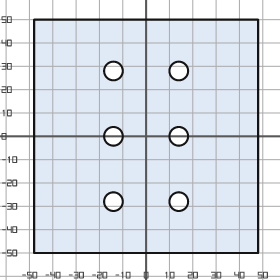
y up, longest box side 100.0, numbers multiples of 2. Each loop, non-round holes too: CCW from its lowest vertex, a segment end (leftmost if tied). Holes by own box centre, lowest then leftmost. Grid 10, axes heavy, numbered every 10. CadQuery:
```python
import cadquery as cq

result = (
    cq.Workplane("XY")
    .moveTo(-48.0, -50.0)
    .lineTo(48.0, -50.0)
    .lineTo(48.0, 50.0)
    .lineTo(-48.0, 50.0)
    .close()
    .moveTo(-14.0, -28.0)
    .circle(4.0)
    .moveTo(14.0, -28.0)
    .circle(4.0)
    .moveTo(-14.0, 0.0)
    .circle(4.0)
    .moveTo(14.0, 0.0)
    .circle(4.0)
    .moveTo(-14.0, 28.0)
    .circle(4.0)
    .moveTo(14.0, 28.0)
    .circle(4.0)
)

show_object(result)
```